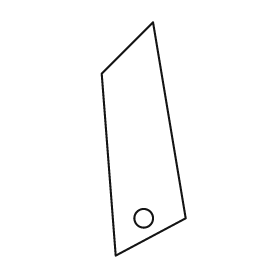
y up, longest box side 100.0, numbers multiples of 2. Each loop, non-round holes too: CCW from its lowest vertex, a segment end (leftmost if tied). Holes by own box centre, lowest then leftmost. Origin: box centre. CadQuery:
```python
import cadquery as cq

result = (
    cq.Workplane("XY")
    .moveTo(-12.0, -50.0)
    .lineTo(18.0, -34.0)
    .lineTo(4.0, 50.0)
    .lineTo(-18.0, 28.0)
    .close()
    .moveTo(0.0, -34.0)
    .circle(4.0)
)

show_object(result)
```